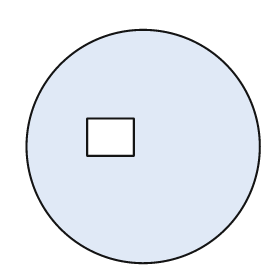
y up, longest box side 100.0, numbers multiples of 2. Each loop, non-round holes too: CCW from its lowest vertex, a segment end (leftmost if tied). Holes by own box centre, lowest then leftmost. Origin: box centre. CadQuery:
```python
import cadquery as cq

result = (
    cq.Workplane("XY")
    .moveTo(0.0, 0.0)
    .circle(50.0)
    .moveTo(-24.0, -4.0)
    .lineTo(-4.0, -4.0)
    .lineTo(-4.0, 12.0)
    .lineTo(-24.0, 12.0)
    .close()
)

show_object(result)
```